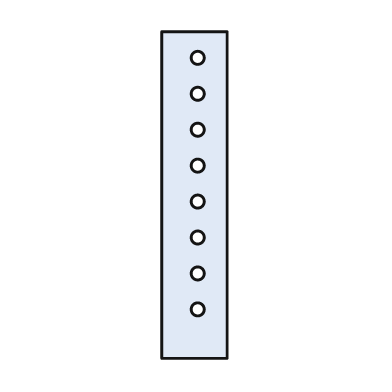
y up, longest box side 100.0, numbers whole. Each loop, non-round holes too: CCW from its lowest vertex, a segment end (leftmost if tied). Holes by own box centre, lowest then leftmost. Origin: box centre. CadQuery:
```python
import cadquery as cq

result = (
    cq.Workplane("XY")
    .moveTo(-10.0, -50.0)
    .lineTo(10.0, -50.0)
    .lineTo(10.0, 50.0)
    .lineTo(-10.0, 50.0)
    .close()
    .moveTo(1.0, -35.0)
    .circle(2.0)
    .moveTo(1.0, -24.0)
    .circle(2.0)
    .moveTo(1.0, -13.0)
    .circle(2.0)
    .moveTo(1.0, -2.0)
    .circle(2.0)
    .moveTo(1.0, 9.0)
    .circle(2.0)
    .moveTo(1.0, 20.0)
    .circle(2.0)
    .moveTo(1.0, 31.0)
    .circle(2.0)
    .moveTo(1.0, 42.0)
    .circle(2.0)
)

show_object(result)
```